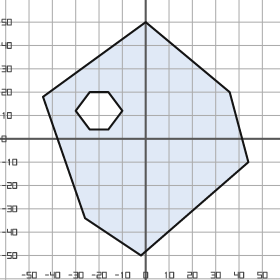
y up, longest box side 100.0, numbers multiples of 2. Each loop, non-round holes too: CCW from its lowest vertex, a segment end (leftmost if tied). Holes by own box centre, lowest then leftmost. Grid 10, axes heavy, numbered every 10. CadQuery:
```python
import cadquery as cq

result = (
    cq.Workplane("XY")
    .moveTo(-2.0, -50.0)
    .lineTo(44.0, -10.0)
    .lineTo(36.0, 20.0)
    .lineTo(0.0, 50.0)
    .lineTo(-44.0, 18.0)
    .lineTo(-26.0, -34.0)
    .close()
    .moveTo(-24.0, 4.0)
    .lineTo(-16.0, 4.0)
    .lineTo(-10.0, 12.0)
    .lineTo(-16.0, 20.0)
    .lineTo(-24.0, 20.0)
    .lineTo(-30.0, 12.0)
    .close()
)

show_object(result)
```